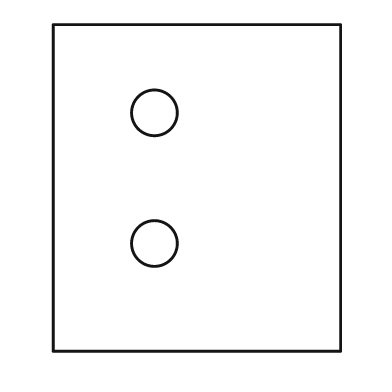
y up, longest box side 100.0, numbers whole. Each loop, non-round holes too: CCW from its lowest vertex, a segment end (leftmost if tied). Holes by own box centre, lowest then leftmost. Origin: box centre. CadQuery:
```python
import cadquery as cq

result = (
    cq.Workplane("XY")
    .moveTo(-44.0, -50.0)
    .lineTo(44.0, -50.0)
    .lineTo(44.0, 50.0)
    .lineTo(-44.0, 50.0)
    .close()
    .moveTo(-13.0, -17.0)
    .circle(7.0)
    .moveTo(-13.0, 23.0)
    .circle(7.0)
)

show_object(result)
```